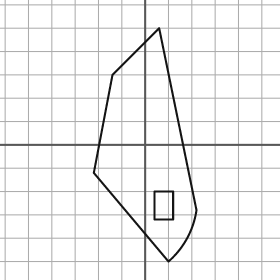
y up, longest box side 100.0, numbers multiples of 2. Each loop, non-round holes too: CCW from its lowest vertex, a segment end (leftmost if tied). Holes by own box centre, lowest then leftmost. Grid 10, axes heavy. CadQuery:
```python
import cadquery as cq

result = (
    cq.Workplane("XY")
    .moveTo(10.0, -50.0)
    .threePointArc((18.0, -40.0), (22.0, -28.0))
    .lineTo(6.0, 50.0)
    .lineTo(-14.0, 30.0)
    .lineTo(-22.0, -12.0)
    .close()
    .moveTo(4.0, -32.0)
    .lineTo(12.0, -32.0)
    .lineTo(12.0, -20.0)
    .lineTo(4.0, -20.0)
    .close()
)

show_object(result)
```